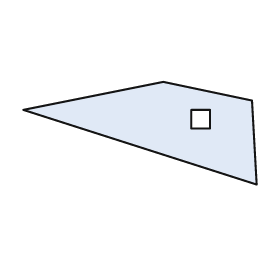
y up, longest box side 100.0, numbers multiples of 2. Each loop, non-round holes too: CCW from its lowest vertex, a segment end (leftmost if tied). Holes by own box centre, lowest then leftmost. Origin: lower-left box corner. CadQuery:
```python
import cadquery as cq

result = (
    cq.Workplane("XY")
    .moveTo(100.0, 0.0)
    .lineTo(98.0, 36.0)
    .lineTo(60.0, 44.0)
    .lineTo(0.0, 32.0)
    .close()
    .moveTo(72.0, 24.0)
    .lineTo(80.0, 24.0)
    .lineTo(80.0, 32.0)
    .lineTo(72.0, 32.0)
    .close()
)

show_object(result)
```